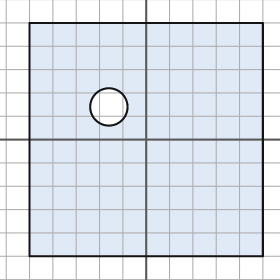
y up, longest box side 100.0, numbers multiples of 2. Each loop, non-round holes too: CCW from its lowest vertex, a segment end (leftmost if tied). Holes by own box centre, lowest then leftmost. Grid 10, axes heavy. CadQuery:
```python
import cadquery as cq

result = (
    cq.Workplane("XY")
    .moveTo(-50.0, -50.0)
    .lineTo(50.0, -50.0)
    .lineTo(50.0, 50.0)
    .lineTo(-50.0, 50.0)
    .close()
    .moveTo(-16.0, 14.0)
    .circle(8.0)
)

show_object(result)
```